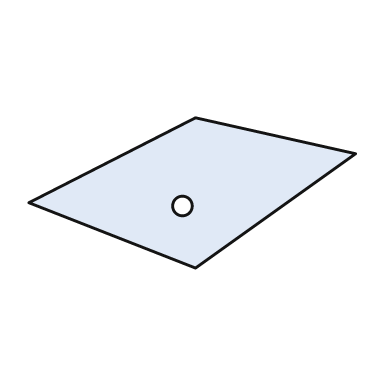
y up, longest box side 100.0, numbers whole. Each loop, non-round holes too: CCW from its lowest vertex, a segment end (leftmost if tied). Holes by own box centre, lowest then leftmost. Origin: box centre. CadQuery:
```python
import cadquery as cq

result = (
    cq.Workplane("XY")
    .moveTo(1.0, -23.0)
    .lineTo(50.0, 12.0)
    .lineTo(1.0, 23.0)
    .lineTo(-50.0, -3.0)
    .close()
    .moveTo(-3.0, -4.0)
    .circle(3.0)
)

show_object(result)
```